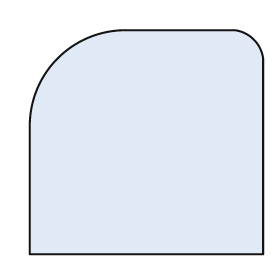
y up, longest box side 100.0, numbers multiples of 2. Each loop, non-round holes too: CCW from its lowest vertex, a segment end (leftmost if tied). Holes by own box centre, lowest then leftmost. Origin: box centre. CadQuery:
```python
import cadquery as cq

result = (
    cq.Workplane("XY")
    .moveTo(-50.0, -48.0)
    .lineTo(50.0, -48.0)
    .lineTo(50.0, 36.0)
    .threePointArc((46.0, 44.0), (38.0, 48.0))
    .lineTo(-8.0, 48.0)
    .threePointArc((-38.0, 36.0), (-50.0, 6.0))
    .close()
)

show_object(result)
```